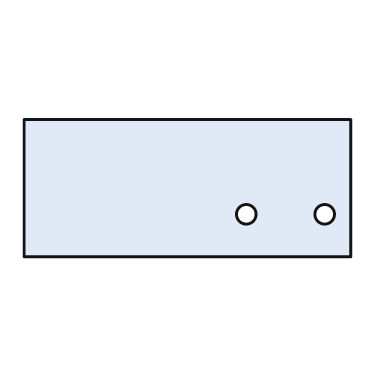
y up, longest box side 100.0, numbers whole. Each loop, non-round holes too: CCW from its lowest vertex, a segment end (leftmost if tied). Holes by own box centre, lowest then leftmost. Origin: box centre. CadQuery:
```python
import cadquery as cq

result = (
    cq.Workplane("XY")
    .moveTo(-50.0, -21.0)
    .lineTo(50.0, -21.0)
    .lineTo(50.0, 21.0)
    .lineTo(-50.0, 21.0)
    .close()
    .moveTo(18.0, -8.0)
    .circle(3.0)
    .moveTo(42.0, -8.0)
    .circle(3.0)
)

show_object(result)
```